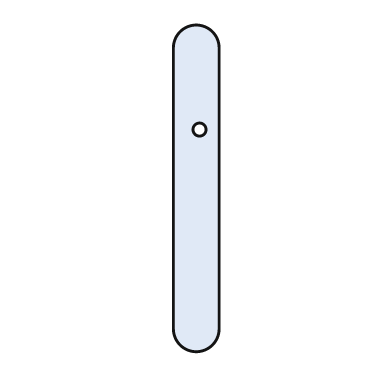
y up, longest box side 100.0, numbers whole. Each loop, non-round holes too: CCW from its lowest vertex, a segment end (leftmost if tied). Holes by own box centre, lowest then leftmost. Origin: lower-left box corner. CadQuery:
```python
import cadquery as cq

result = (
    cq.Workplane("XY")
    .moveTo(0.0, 7.0)
    .threePointArc((7.0, 0.0), (14.0, 7.0))
    .lineTo(14.0, 93.0)
    .threePointArc((7.0, 100.0), (0.0, 93.0))
    .close()
    .moveTo(8.0, 68.0)
    .circle(2.0)
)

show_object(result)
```